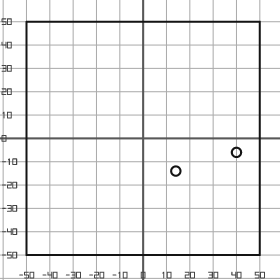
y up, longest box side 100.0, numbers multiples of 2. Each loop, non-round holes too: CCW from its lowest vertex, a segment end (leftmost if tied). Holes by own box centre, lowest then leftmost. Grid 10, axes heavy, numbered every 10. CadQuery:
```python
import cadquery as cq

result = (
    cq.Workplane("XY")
    .moveTo(-50.0, -50.0)
    .lineTo(50.0, -50.0)
    .lineTo(50.0, 50.0)
    .lineTo(-50.0, 50.0)
    .close()
    .moveTo(14.0, -14.0)
    .circle(2.0)
    .moveTo(40.0, -6.0)
    .circle(2.0)
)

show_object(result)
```